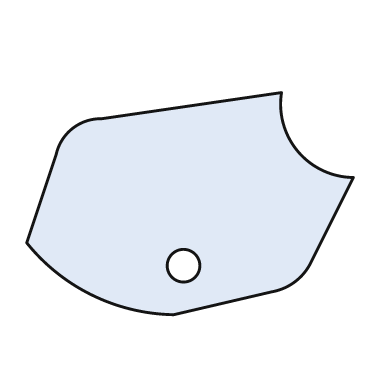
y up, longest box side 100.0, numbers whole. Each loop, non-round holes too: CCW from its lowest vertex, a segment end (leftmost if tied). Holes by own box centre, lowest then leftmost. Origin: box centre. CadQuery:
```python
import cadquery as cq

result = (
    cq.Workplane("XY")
    .moveTo(-5.0, -34.0)
    .lineTo(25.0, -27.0)
    .threePointArc((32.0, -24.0), (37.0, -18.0))
    .lineTo(50.0, 8.0)
    .threePointArc((33.0, 16.0), (28.0, 34.0))
    .lineTo(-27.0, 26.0)
    .threePointArc((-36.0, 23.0), (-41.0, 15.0))
    .lineTo(-50.0, -12.0)
    .threePointArc((-30.0, -28.0), (-5.0, -34.0))
    .close()
    .moveTo(-2.0, -19.0)
    .circle(5.0)
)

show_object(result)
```